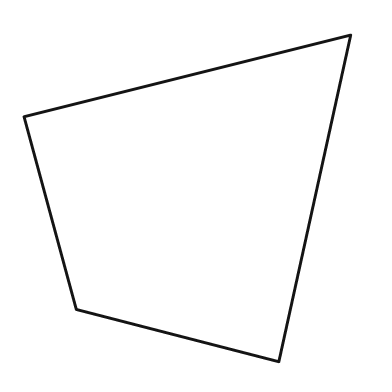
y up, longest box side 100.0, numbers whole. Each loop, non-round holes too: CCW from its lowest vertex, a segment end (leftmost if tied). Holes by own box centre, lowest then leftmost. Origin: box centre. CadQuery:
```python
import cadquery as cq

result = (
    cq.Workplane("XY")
    .moveTo(28.0, -50.0)
    .lineTo(50.0, 50.0)
    .lineTo(-50.0, 25.0)
    .lineTo(-34.0, -34.0)
    .close()
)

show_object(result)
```